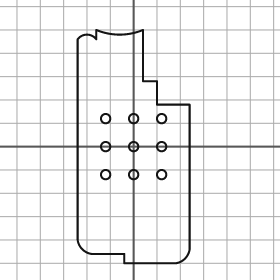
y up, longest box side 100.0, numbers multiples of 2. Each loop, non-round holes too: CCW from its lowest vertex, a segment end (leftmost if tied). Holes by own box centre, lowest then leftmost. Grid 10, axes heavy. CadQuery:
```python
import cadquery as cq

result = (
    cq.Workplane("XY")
    .moveTo(-4.0, -50.0)
    .lineTo(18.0, -50.0)
    .threePointArc((22.0, -48.0), (24.0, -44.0))
    .lineTo(24.0, 18.0)
    .lineTo(10.0, 18.0)
    .lineTo(10.0, 28.0)
    .lineTo(4.0, 28.0)
    .lineTo(4.0, 50.0)
    .threePointArc((-6.0, 48.0), (-16.0, 50.0))
    .lineTo(-16.0, 46.0)
    .threePointArc((-20.0, 48.0), (-24.0, 46.0))
    .lineTo(-24.0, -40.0)
    .threePointArc((-22.0, -44.0), (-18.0, -46.0))
    .lineTo(-4.0, -46.0)
    .close()
    .moveTo(-12.0, -12.0)
    .circle(2.0)
    .moveTo(0.0, -12.0)
    .circle(2.0)
    .moveTo(12.0, -12.0)
    .circle(2.0)
    .moveTo(-12.0, 0.0)
    .circle(2.0)
    .moveTo(0.0, 0.0)
    .circle(2.0)
    .moveTo(12.0, 0.0)
    .circle(2.0)
    .moveTo(-12.0, 12.0)
    .circle(2.0)
    .moveTo(0.0, 12.0)
    .circle(2.0)
    .moveTo(12.0, 12.0)
    .circle(2.0)
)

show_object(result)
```